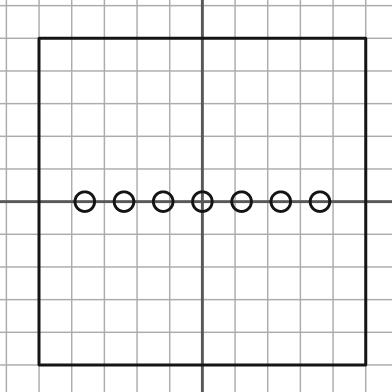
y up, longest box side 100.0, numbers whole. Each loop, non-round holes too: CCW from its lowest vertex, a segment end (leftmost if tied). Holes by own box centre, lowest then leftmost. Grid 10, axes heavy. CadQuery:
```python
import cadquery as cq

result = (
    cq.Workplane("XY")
    .moveTo(-50.0, -50.0)
    .lineTo(50.0, -50.0)
    .lineTo(50.0, 50.0)
    .lineTo(-50.0, 50.0)
    .close()
    .moveTo(-36.0, 0.0)
    .circle(3.0)
    .moveTo(-24.0, 0.0)
    .circle(3.0)
    .moveTo(-12.0, 0.0)
    .circle(3.0)
    .moveTo(0.0, 0.0)
    .circle(3.0)
    .moveTo(12.0, 0.0)
    .circle(3.0)
    .moveTo(24.0, 0.0)
    .circle(3.0)
    .moveTo(36.0, 0.0)
    .circle(3.0)
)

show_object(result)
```